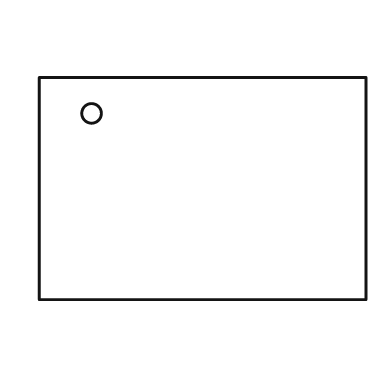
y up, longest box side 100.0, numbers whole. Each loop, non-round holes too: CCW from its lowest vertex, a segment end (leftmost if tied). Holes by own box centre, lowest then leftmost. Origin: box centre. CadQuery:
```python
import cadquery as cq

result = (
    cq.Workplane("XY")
    .moveTo(-50.0, -34.0)
    .lineTo(50.0, -34.0)
    .lineTo(50.0, 34.0)
    .lineTo(-50.0, 34.0)
    .close()
    .moveTo(-34.0, 23.0)
    .circle(3.0)
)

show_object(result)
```